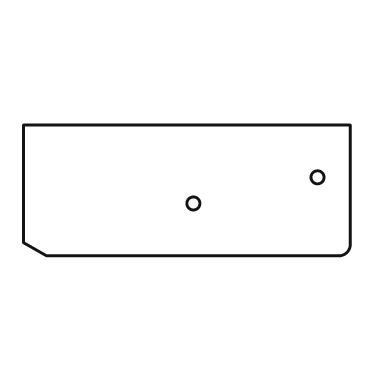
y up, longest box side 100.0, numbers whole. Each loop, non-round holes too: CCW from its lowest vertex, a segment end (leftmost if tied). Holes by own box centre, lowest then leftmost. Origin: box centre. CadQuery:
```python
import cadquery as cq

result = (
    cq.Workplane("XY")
    .moveTo(-43.0, -20.0)
    .lineTo(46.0, -20.0)
    .threePointArc((49.0, -19.0), (50.0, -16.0))
    .lineTo(50.0, 20.0)
    .lineTo(-50.0, 20.0)
    .lineTo(-50.0, -16.0)
    .close()
    .moveTo(2.0, -4.0)
    .circle(2.0)
    .moveTo(40.0, 4.0)
    .circle(2.0)
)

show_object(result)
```